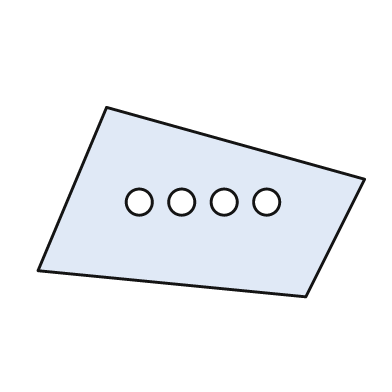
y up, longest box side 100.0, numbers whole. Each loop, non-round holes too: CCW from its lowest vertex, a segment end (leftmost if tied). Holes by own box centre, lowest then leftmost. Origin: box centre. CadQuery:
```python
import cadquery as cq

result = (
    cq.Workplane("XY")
    .moveTo(32.0, -29.0)
    .lineTo(50.0, 7.0)
    .lineTo(-29.0, 29.0)
    .lineTo(-50.0, -21.0)
    .close()
    .moveTo(-19.0, 0.0)
    .circle(4.0)
    .moveTo(-6.0, 0.0)
    .circle(4.0)
    .moveTo(7.0, 0.0)
    .circle(4.0)
    .moveTo(20.0, 0.0)
    .circle(4.0)
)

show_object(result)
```